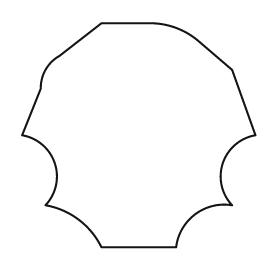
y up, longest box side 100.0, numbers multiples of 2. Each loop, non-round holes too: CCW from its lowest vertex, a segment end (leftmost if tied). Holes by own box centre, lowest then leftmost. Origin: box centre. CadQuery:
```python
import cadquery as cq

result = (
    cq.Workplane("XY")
    .moveTo(-16.0, -48.0)
    .lineTo(16.0, -48.0)
    .threePointArc((24.0, -34.0), (40.0, -30.0))
    .threePointArc((36.0, -12.0), (50.0, 0.0))
    .lineTo(40.0, 28.0)
    .lineTo(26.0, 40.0)
    .threePointArc((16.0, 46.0), (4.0, 48.0))
    .lineTo(-16.0, 48.0)
    .lineTo(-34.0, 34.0)
    .threePointArc((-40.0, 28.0), (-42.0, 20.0))
    .lineTo(-50.0, 0.0)
    .threePointArc((-36.0, -12.0), (-40.0, -30.0))
    .threePointArc((-26.0, -36.0), (-16.0, -48.0))
    .close()
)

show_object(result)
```